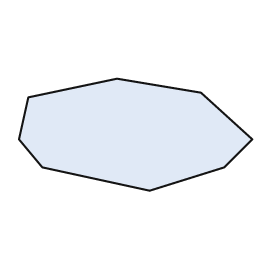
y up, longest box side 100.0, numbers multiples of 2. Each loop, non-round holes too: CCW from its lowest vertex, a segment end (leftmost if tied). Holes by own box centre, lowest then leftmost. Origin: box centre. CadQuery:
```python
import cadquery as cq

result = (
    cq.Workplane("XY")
    .moveTo(6.0, -24.0)
    .lineTo(38.0, -14.0)
    .lineTo(50.0, -2.0)
    .lineTo(28.0, 18.0)
    .lineTo(-8.0, 24.0)
    .lineTo(-46.0, 16.0)
    .lineTo(-50.0, -2.0)
    .lineTo(-40.0, -14.0)
    .close()
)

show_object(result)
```